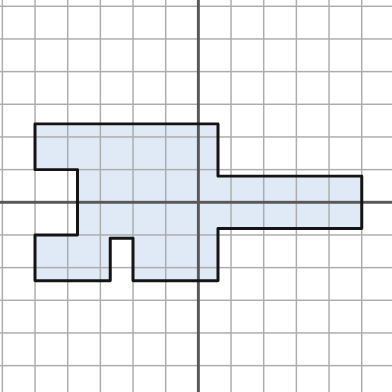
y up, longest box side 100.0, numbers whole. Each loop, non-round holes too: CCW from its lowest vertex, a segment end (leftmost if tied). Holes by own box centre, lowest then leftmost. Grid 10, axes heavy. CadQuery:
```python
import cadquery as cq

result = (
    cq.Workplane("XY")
    .moveTo(-50.0, -24.0)
    .lineTo(-27.0, -24.0)
    .lineTo(-27.0, -11.0)
    .lineTo(-20.0, -11.0)
    .lineTo(-20.0, -24.0)
    .lineTo(6.0, -24.0)
    .lineTo(6.0, -8.0)
    .lineTo(50.0, -8.0)
    .lineTo(50.0, 8.0)
    .lineTo(6.0, 8.0)
    .lineTo(6.0, 24.0)
    .lineTo(-50.0, 24.0)
    .lineTo(-50.0, 10.0)
    .lineTo(-37.0, 10.0)
    .lineTo(-37.0, -10.0)
    .lineTo(-50.0, -10.0)
    .close()
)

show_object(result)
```